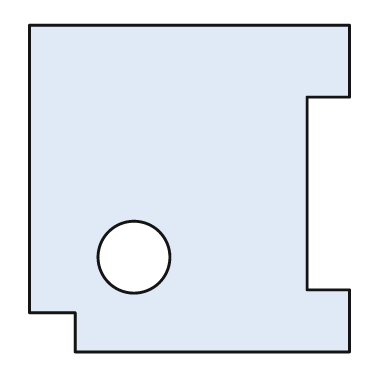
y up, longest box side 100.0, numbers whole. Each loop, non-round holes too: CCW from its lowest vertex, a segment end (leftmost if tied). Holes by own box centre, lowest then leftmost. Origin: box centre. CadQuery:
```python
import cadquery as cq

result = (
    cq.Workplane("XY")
    .moveTo(-35.0, -50.0)
    .lineTo(49.0, -50.0)
    .lineTo(49.0, -31.0)
    .lineTo(36.0, -31.0)
    .lineTo(36.0, 28.0)
    .lineTo(49.0, 28.0)
    .lineTo(49.0, 50.0)
    .lineTo(-49.0, 50.0)
    .lineTo(-49.0, -38.0)
    .lineTo(-35.0, -38.0)
    .close()
    .moveTo(-17.0, -21.0)
    .circle(11.0)
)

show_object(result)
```